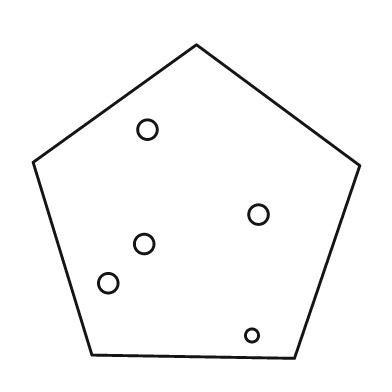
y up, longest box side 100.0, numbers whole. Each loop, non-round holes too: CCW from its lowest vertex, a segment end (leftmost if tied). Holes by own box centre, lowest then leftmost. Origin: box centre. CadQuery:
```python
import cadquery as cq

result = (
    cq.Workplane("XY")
    .moveTo(30.0, -48.0)
    .lineTo(50.0, 11.0)
    .lineTo(0.0, 48.0)
    .lineTo(-50.0, 12.0)
    .lineTo(-32.0, -47.0)
    .close()
    .moveTo(17.0, -41.0)
    .circle(2.0)
    .moveTo(-27.0, -25.0)
    .circle(3.0)
    .moveTo(-16.0, -13.0)
    .circle(3.0)
    .moveTo(19.0, -4.0)
    .circle(3.0)
    .moveTo(-15.0, 22.0)
    .circle(3.0)
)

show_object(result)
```